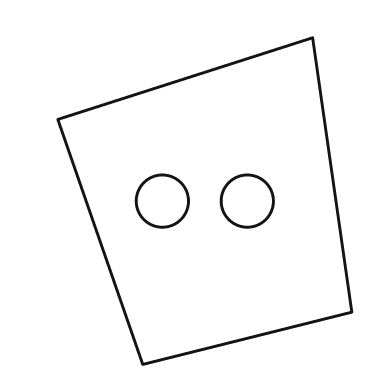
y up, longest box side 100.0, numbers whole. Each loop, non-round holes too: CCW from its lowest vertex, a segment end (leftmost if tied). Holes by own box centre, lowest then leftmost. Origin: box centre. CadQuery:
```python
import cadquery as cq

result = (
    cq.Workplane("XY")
    .moveTo(-19.0, -50.0)
    .lineTo(45.0, -34.0)
    .lineTo(33.0, 50.0)
    .lineTo(-45.0, 25.0)
    .close()
    .moveTo(-13.0, 0.0)
    .circle(8.0)
    .moveTo(13.0, 0.0)
    .circle(8.0)
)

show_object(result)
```